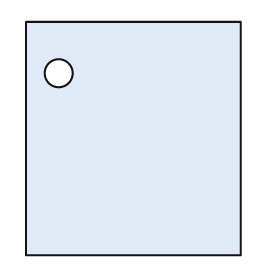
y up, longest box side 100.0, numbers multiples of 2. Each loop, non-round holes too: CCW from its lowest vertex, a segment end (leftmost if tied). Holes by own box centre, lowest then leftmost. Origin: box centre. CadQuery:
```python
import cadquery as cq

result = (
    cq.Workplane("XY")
    .moveTo(-46.0, -50.0)
    .lineTo(46.0, -50.0)
    .lineTo(46.0, 50.0)
    .lineTo(-46.0, 50.0)
    .close()
    .moveTo(-32.0, 28.0)
    .circle(6.0)
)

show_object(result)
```